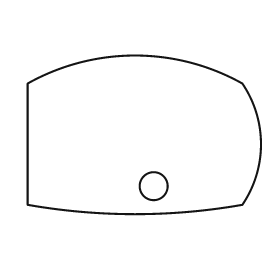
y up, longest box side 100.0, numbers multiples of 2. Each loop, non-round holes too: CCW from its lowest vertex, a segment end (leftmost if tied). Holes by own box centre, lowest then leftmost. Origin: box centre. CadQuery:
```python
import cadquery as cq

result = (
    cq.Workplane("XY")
    .moveTo(-50.0, -30.0)
    .threePointArc((-4.0, -34.0), (42.0, -30.0))
    .threePointArc((50.0, -4.0), (42.0, 22.0))
    .threePointArc((-4.0, 34.0), (-50.0, 22.0))
    .close()
    .moveTo(4.0, -22.0)
    .circle(6.0)
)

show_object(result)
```